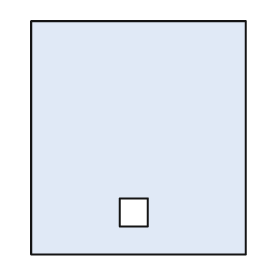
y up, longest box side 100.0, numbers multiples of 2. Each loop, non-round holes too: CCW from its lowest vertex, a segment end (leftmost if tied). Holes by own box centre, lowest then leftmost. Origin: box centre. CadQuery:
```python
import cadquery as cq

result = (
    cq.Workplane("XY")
    .moveTo(-46.0, -50.0)
    .lineTo(46.0, -50.0)
    .lineTo(46.0, 50.0)
    .lineTo(-46.0, 50.0)
    .close()
    .moveTo(-8.0, -38.0)
    .lineTo(4.0, -38.0)
    .lineTo(4.0, -26.0)
    .lineTo(-8.0, -26.0)
    .close()
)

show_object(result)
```